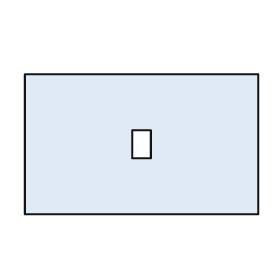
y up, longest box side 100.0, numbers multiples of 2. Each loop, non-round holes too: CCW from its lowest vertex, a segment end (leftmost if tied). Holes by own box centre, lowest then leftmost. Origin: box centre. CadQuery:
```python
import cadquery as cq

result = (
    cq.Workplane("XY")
    .moveTo(-50.0, -30.0)
    .lineTo(50.0, -30.0)
    .lineTo(50.0, 30.0)
    .lineTo(-50.0, 30.0)
    .close()
    .moveTo(-4.0, -6.0)
    .lineTo(4.0, -6.0)
    .lineTo(4.0, 6.0)
    .lineTo(-4.0, 6.0)
    .close()
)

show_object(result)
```